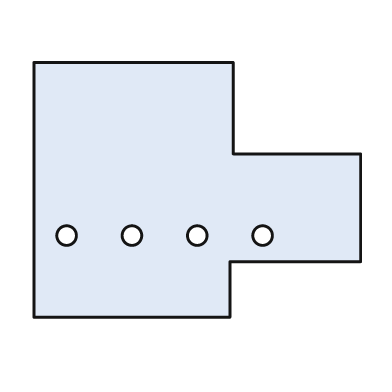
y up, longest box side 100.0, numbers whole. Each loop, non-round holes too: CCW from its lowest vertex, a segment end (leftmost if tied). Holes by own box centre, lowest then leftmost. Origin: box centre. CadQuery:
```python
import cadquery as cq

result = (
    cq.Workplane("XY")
    .moveTo(-50.0, -39.0)
    .lineTo(10.0, -39.0)
    .lineTo(10.0, -22.0)
    .lineTo(50.0, -22.0)
    .lineTo(50.0, 11.0)
    .lineTo(11.0, 11.0)
    .lineTo(11.0, 39.0)
    .lineTo(-50.0, 39.0)
    .close()
    .moveTo(-40.0, -14.0)
    .circle(3.0)
    .moveTo(-20.0, -14.0)
    .circle(3.0)
    .moveTo(0.0, -14.0)
    .circle(3.0)
    .moveTo(20.0, -14.0)
    .circle(3.0)
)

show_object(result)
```